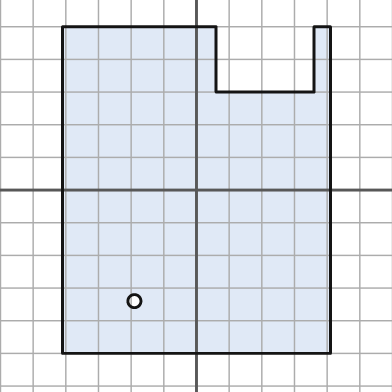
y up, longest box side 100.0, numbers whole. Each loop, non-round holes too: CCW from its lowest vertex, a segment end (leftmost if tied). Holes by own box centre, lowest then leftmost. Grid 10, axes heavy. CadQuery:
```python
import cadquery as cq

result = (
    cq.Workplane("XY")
    .moveTo(-41.0, -50.0)
    .lineTo(41.0, -50.0)
    .lineTo(41.0, 50.0)
    .lineTo(36.0, 50.0)
    .lineTo(36.0, 30.0)
    .lineTo(6.0, 30.0)
    .lineTo(6.0, 50.0)
    .lineTo(-41.0, 50.0)
    .close()
    .moveTo(-19.0, -34.0)
    .circle(2.0)
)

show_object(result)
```